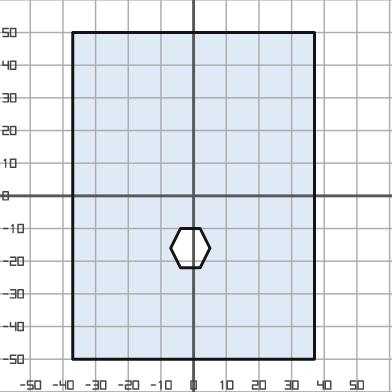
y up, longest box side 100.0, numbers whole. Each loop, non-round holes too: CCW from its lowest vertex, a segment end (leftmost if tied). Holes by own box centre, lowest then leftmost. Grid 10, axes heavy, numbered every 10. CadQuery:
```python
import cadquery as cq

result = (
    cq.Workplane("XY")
    .moveTo(-37.0, -50.0)
    .lineTo(37.0, -50.0)
    .lineTo(37.0, 50.0)
    .lineTo(-37.0, 50.0)
    .close()
    .moveTo(-4.0, -22.0)
    .lineTo(2.0, -22.0)
    .lineTo(5.0, -16.0)
    .lineTo(2.0, -10.0)
    .lineTo(-4.0, -10.0)
    .lineTo(-7.0, -16.0)
    .close()
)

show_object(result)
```